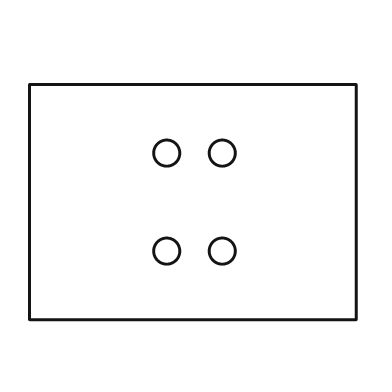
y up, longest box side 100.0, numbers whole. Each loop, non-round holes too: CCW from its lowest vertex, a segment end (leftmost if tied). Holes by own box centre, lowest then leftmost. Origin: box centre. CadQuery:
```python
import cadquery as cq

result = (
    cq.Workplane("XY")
    .moveTo(-50.0, -36.0)
    .lineTo(50.0, -36.0)
    .lineTo(50.0, 36.0)
    .lineTo(-50.0, 36.0)
    .close()
    .moveTo(-8.0, -15.0)
    .circle(4.0)
    .moveTo(9.0, -15.0)
    .circle(4.0)
    .moveTo(-8.0, 15.0)
    .circle(4.0)
    .moveTo(9.0, 15.0)
    .circle(4.0)
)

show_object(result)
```